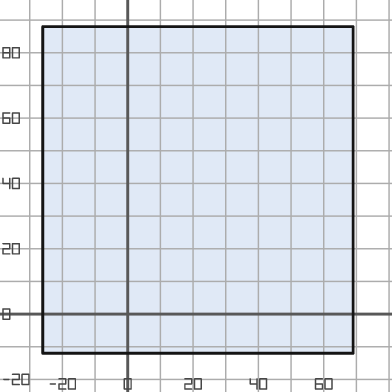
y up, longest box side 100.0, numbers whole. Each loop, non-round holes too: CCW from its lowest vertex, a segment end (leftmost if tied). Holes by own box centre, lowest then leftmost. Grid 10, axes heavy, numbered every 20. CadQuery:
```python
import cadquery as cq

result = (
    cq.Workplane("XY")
    .moveTo(-26.0, -12.0)
    .lineTo(69.0, -12.0)
    .lineTo(69.0, 88.0)
    .lineTo(-26.0, 88.0)
    .close()
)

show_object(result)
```